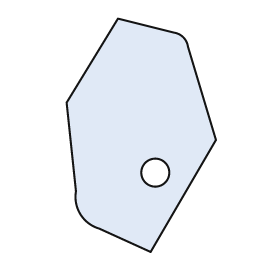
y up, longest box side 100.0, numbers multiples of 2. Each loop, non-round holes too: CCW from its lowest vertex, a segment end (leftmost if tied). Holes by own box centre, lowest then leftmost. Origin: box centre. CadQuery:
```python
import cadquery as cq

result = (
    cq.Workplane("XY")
    .moveTo(4.0, -50.0)
    .lineTo(32.0, -2.0)
    .lineTo(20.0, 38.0)
    .threePointArc((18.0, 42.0), (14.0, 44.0))
    .lineTo(-10.0, 50.0)
    .lineTo(-32.0, 14.0)
    .lineTo(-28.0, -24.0)
    .threePointArc((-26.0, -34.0), (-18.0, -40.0))
    .close()
    .moveTo(6.0, -16.0)
    .circle(6.0)
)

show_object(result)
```